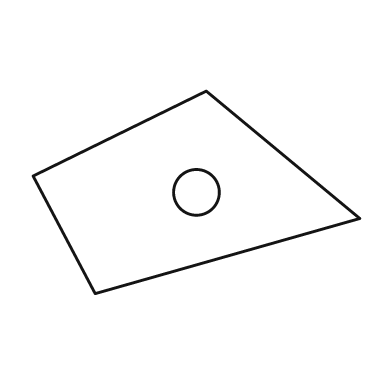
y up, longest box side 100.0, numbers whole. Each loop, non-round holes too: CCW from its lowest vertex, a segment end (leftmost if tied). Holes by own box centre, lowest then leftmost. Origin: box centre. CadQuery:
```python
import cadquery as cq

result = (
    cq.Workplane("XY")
    .moveTo(-31.0, -31.0)
    .lineTo(50.0, -8.0)
    .lineTo(3.0, 31.0)
    .lineTo(-50.0, 5.0)
    .close()
    .moveTo(0.0, 0.0)
    .circle(7.0)
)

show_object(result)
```